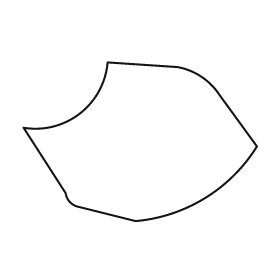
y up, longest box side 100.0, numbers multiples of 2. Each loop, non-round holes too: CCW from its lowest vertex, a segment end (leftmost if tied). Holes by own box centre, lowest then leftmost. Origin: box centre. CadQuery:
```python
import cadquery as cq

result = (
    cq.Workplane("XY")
    .moveTo(-2.0, -34.0)
    .threePointArc((28.0, -24.0), (50.0, -2.0))
    .lineTo(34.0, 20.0)
    .threePointArc((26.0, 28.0), (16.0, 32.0))
    .lineTo(-14.0, 34.0)
    .threePointArc((-26.0, 12.0), (-50.0, 6.0))
    .lineTo(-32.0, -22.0)
    .threePointArc((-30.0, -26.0), (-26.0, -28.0))
    .close()
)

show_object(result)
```